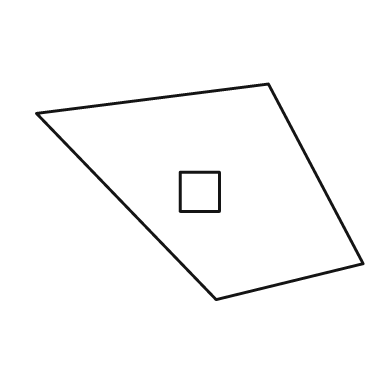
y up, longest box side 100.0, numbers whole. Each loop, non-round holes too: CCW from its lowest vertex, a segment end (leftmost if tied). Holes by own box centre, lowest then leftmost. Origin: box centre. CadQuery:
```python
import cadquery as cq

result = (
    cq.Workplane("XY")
    .moveTo(5.0, -33.0)
    .lineTo(50.0, -22.0)
    .lineTo(21.0, 33.0)
    .lineTo(-50.0, 24.0)
    .close()
    .moveTo(-6.0, -6.0)
    .lineTo(6.0, -6.0)
    .lineTo(6.0, 6.0)
    .lineTo(-6.0, 6.0)
    .close()
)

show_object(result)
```